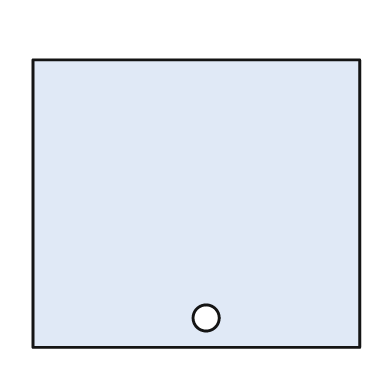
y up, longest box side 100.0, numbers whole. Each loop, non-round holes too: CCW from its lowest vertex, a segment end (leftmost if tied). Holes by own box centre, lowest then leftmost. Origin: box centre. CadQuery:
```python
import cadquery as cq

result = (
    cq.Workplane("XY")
    .moveTo(-50.0, -44.0)
    .lineTo(50.0, -44.0)
    .lineTo(50.0, 44.0)
    .lineTo(-50.0, 44.0)
    .close()
    .moveTo(3.0, -35.0)
    .circle(4.0)
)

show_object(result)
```